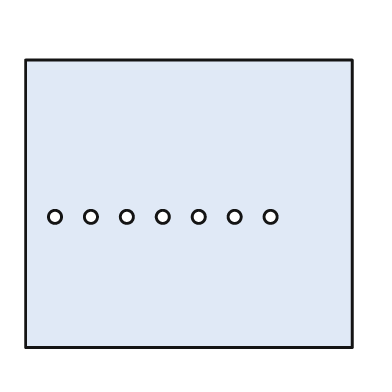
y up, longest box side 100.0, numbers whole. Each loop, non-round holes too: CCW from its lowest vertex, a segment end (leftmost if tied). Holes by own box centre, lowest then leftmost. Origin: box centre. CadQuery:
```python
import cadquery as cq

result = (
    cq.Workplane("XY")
    .moveTo(-50.0, -44.0)
    .lineTo(50.0, -44.0)
    .lineTo(50.0, 44.0)
    .lineTo(-50.0, 44.0)
    .close()
    .moveTo(-41.0, -4.0)
    .circle(2.0)
    .moveTo(-30.0, -4.0)
    .circle(2.0)
    .moveTo(-19.0, -4.0)
    .circle(2.0)
    .moveTo(-8.0, -4.0)
    .circle(2.0)
    .moveTo(3.0, -4.0)
    .circle(2.0)
    .moveTo(14.0, -4.0)
    .circle(2.0)
    .moveTo(25.0, -4.0)
    .circle(2.0)
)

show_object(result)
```